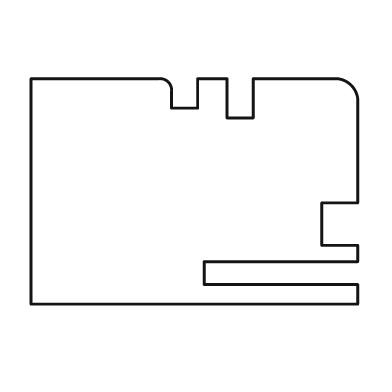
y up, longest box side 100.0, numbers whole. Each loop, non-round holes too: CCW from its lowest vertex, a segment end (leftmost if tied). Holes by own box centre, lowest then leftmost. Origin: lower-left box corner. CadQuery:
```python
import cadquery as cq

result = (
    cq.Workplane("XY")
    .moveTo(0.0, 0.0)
    .lineTo(100.0, 0.0)
    .lineTo(100.0, 6.0)
    .lineTo(53.0, 6.0)
    .lineTo(53.0, 13.0)
    .lineTo(100.0, 13.0)
    .lineTo(100.0, 18.0)
    .lineTo(89.0, 18.0)
    .lineTo(89.0, 31.0)
    .lineTo(100.0, 31.0)
    .lineTo(100.0, 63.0)
    .threePointArc((98.0, 67.0), (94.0, 69.0))
    .lineTo(68.0, 69.0)
    .lineTo(68.0, 57.0)
    .lineTo(60.0, 57.0)
    .lineTo(60.0, 69.0)
    .lineTo(51.0, 69.0)
    .lineTo(51.0, 60.0)
    .lineTo(43.0, 60.0)
    .lineTo(43.0, 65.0)
    .threePointArc((42.0, 68.0), (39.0, 69.0))
    .lineTo(0.0, 69.0)
    .close()
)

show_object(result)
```